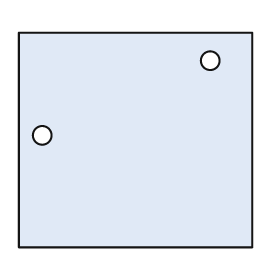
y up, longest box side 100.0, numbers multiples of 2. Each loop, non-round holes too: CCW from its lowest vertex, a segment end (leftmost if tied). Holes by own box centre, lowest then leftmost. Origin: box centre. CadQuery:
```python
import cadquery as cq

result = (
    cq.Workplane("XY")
    .moveTo(-50.0, -46.0)
    .lineTo(50.0, -46.0)
    .lineTo(50.0, 46.0)
    .lineTo(-50.0, 46.0)
    .close()
    .moveTo(-40.0, 2.0)
    .circle(4.0)
    .moveTo(32.0, 34.0)
    .circle(4.0)
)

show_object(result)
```